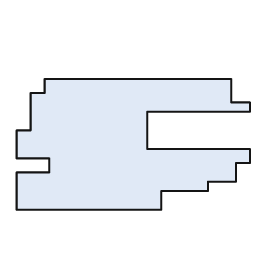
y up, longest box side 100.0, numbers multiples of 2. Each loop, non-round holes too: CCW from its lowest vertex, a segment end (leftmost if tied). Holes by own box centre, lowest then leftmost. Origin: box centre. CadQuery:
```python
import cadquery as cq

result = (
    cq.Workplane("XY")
    .moveTo(-50.0, -28.0)
    .lineTo(12.0, -28.0)
    .lineTo(12.0, -20.0)
    .lineTo(32.0, -20.0)
    .lineTo(32.0, -16.0)
    .lineTo(44.0, -16.0)
    .lineTo(44.0, -8.0)
    .lineTo(50.0, -8.0)
    .lineTo(50.0, -2.0)
    .lineTo(6.0, -2.0)
    .lineTo(6.0, 14.0)
    .lineTo(50.0, 14.0)
    .lineTo(50.0, 18.0)
    .lineTo(42.0, 18.0)
    .lineTo(42.0, 28.0)
    .lineTo(-38.0, 28.0)
    .lineTo(-38.0, 22.0)
    .lineTo(-44.0, 22.0)
    .lineTo(-44.0, 6.0)
    .lineTo(-50.0, 6.0)
    .lineTo(-50.0, -6.0)
    .lineTo(-36.0, -6.0)
    .lineTo(-36.0, -12.0)
    .lineTo(-50.0, -12.0)
    .close()
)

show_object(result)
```